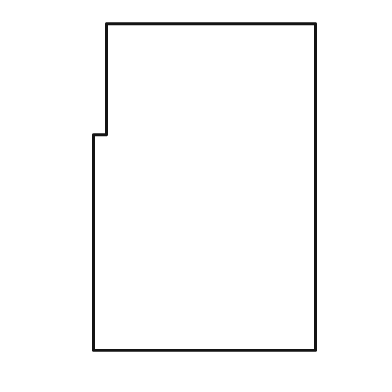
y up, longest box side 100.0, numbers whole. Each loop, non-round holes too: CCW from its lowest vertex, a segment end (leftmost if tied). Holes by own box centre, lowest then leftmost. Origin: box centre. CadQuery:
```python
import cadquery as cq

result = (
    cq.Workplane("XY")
    .moveTo(-34.0, -50.0)
    .lineTo(34.0, -50.0)
    .lineTo(34.0, 50.0)
    .lineTo(-30.0, 50.0)
    .lineTo(-30.0, 16.0)
    .lineTo(-34.0, 16.0)
    .close()
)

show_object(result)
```